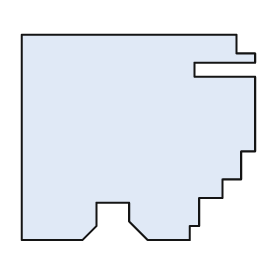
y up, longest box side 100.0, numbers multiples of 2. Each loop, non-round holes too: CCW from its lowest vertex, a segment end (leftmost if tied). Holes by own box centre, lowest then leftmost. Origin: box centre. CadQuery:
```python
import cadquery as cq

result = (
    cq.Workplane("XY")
    .moveTo(-50.0, -44.0)
    .lineTo(-24.0, -44.0)
    .lineTo(-18.0, -38.0)
    .lineTo(-18.0, -28.0)
    .lineTo(-4.0, -28.0)
    .lineTo(-4.0, -36.0)
    .lineTo(4.0, -44.0)
    .lineTo(22.0, -44.0)
    .lineTo(22.0, -38.0)
    .lineTo(26.0, -38.0)
    .lineTo(26.0, -26.0)
    .lineTo(36.0, -26.0)
    .lineTo(36.0, -18.0)
    .lineTo(44.0, -18.0)
    .lineTo(44.0, -6.0)
    .lineTo(50.0, -6.0)
    .lineTo(50.0, 26.0)
    .lineTo(24.0, 26.0)
    .lineTo(24.0, 32.0)
    .lineTo(50.0, 32.0)
    .lineTo(50.0, 36.0)
    .lineTo(42.0, 36.0)
    .lineTo(42.0, 44.0)
    .lineTo(-50.0, 44.0)
    .close()
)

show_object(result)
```